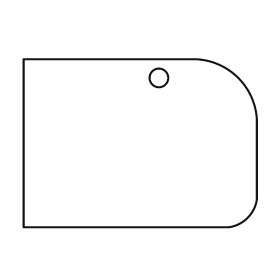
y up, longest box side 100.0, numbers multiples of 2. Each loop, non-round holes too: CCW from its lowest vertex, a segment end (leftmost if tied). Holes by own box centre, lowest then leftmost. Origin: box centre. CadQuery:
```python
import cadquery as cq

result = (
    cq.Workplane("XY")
    .moveTo(-50.0, -36.0)
    .lineTo(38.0, -36.0)
    .threePointArc((46.0, -32.0), (50.0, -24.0))
    .lineTo(50.0, 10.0)
    .threePointArc((42.0, 28.0), (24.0, 36.0))
    .lineTo(-50.0, 36.0)
    .close()
    .moveTo(8.0, 28.0)
    .circle(4.0)
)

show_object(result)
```